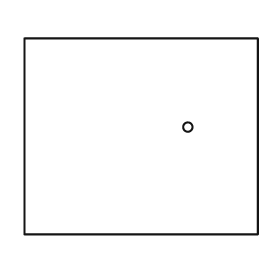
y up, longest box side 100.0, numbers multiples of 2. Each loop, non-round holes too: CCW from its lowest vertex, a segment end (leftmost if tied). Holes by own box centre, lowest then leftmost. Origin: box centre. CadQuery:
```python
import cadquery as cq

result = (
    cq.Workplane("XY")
    .moveTo(-50.0, -42.0)
    .lineTo(50.0, -42.0)
    .lineTo(50.0, 42.0)
    .lineTo(-50.0, 42.0)
    .close()
    .moveTo(20.0, 4.0)
    .circle(2.0)
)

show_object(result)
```